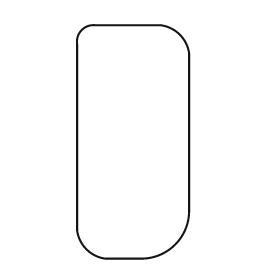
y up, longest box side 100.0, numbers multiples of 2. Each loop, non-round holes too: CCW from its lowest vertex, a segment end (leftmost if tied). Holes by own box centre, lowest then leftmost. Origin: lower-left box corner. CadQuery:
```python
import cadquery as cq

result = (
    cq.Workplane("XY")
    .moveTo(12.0, 0.0)
    .lineTo(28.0, 0.0)
    .threePointArc((42.0, 6.0), (48.0, 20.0))
    .lineTo(48.0, 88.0)
    .threePointArc((44.0, 96.0), (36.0, 100.0))
    .lineTo(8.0, 100.0)
    .threePointArc((2.0, 98.0), (0.0, 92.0))
    .lineTo(0.0, 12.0)
    .threePointArc((4.0, 4.0), (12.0, 0.0))
    .close()
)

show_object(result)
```